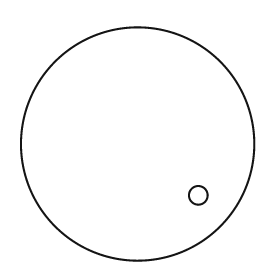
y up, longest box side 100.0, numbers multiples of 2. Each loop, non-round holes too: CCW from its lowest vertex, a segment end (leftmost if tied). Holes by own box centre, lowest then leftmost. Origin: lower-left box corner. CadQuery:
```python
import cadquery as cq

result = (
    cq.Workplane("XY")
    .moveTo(50.0, 50.0)
    .circle(50.0)
    .moveTo(76.0, 28.0)
    .circle(4.0)
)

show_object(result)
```